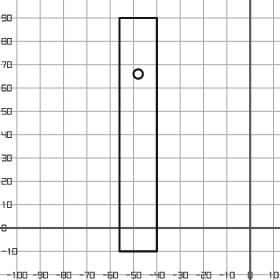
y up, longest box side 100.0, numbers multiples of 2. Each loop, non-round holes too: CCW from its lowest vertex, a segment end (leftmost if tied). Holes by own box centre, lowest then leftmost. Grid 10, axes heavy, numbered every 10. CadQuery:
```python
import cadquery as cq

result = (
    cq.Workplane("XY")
    .moveTo(-56.0, -10.0)
    .lineTo(-40.0, -10.0)
    .lineTo(-40.0, 90.0)
    .lineTo(-56.0, 90.0)
    .close()
    .moveTo(-48.0, 66.0)
    .circle(2.0)
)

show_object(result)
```